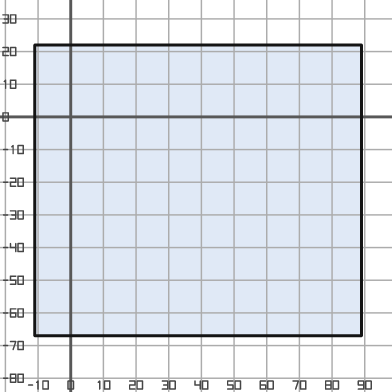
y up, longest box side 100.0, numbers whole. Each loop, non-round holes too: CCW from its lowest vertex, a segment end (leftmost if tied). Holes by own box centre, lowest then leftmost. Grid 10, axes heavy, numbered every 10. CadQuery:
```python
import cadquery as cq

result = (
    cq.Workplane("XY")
    .moveTo(-11.0, -67.0)
    .lineTo(89.0, -67.0)
    .lineTo(89.0, 22.0)
    .lineTo(-11.0, 22.0)
    .close()
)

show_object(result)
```